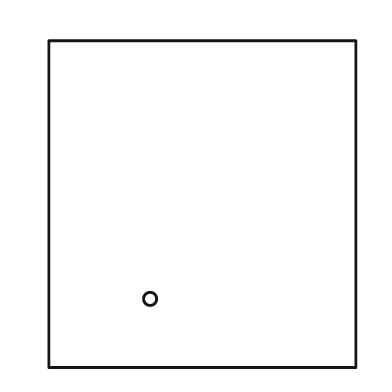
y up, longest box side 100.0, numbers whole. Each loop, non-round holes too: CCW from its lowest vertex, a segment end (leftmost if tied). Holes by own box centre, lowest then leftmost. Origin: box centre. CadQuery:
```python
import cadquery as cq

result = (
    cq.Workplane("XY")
    .moveTo(-47.0, -50.0)
    .lineTo(47.0, -50.0)
    .lineTo(47.0, 50.0)
    .lineTo(-47.0, 50.0)
    .close()
    .moveTo(-16.0, -29.0)
    .circle(2.0)
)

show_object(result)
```